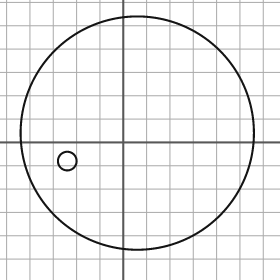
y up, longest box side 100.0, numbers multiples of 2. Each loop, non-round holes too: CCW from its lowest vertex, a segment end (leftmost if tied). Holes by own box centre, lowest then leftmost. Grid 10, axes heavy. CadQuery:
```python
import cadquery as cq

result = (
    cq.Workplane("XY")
    .moveTo(6.0, 4.0)
    .circle(50.0)
    .moveTo(-24.0, -8.0)
    .circle(4.0)
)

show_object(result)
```